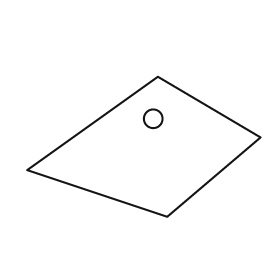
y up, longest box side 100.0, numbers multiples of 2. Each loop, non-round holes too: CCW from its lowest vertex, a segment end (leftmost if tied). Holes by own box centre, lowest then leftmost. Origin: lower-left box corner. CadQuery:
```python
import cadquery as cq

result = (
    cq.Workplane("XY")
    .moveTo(60.0, 0.0)
    .lineTo(100.0, 34.0)
    .lineTo(56.0, 60.0)
    .lineTo(0.0, 20.0)
    .close()
    .moveTo(54.0, 42.0)
    .circle(4.0)
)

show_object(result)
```